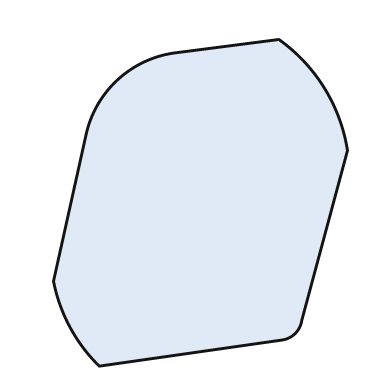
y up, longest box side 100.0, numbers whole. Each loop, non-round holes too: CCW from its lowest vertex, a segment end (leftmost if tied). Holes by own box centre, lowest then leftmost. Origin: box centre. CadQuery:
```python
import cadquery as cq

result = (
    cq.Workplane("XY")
    .moveTo(-31.0, -50.0)
    .lineTo(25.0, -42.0)
    .threePointArc((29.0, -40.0), (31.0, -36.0))
    .lineTo(45.0, 16.0)
    .threePointArc((38.0, 35.0), (24.0, 50.0))
    .lineTo(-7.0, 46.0)
    .threePointArc((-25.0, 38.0), (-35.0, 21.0))
    .lineTo(-45.0, -24.0)
    .threePointArc((-40.0, -38.0), (-31.0, -50.0))
    .close()
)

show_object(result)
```